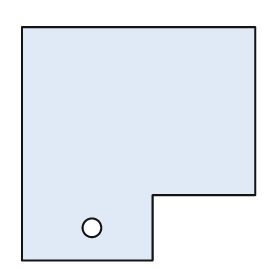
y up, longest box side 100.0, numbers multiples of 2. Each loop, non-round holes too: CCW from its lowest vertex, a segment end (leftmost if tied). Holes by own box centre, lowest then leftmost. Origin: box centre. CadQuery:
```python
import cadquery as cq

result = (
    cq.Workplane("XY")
    .moveTo(-50.0, -50.0)
    .lineTo(6.0, -50.0)
    .lineTo(6.0, -22.0)
    .lineTo(50.0, -22.0)
    .lineTo(50.0, 50.0)
    .lineTo(-50.0, 50.0)
    .close()
    .moveTo(-20.0, -36.0)
    .circle(4.0)
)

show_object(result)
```